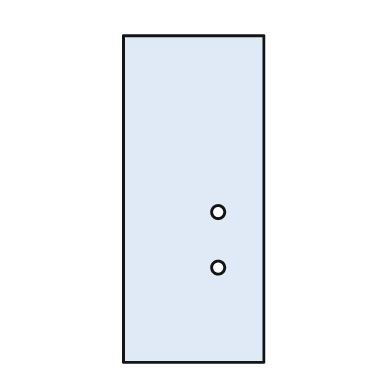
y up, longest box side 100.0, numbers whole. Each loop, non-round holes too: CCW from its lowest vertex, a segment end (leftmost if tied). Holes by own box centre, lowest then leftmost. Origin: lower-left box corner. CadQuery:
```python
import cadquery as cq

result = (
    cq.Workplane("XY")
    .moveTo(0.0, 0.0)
    .lineTo(43.0, 0.0)
    .lineTo(43.0, 100.0)
    .lineTo(0.0, 100.0)
    .close()
    .moveTo(29.0, 29.0)
    .circle(2.0)
    .moveTo(29.0, 46.0)
    .circle(2.0)
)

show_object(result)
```